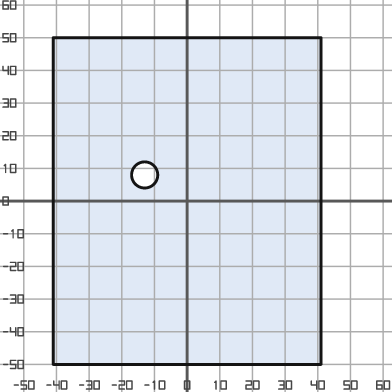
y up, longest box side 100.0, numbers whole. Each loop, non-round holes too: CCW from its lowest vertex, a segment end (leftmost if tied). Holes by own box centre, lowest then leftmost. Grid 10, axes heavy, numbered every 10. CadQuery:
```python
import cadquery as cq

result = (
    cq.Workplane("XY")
    .moveTo(-41.0, -50.0)
    .lineTo(41.0, -50.0)
    .lineTo(41.0, 50.0)
    .lineTo(-41.0, 50.0)
    .close()
    .moveTo(-13.0, 8.0)
    .circle(4.0)
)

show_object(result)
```